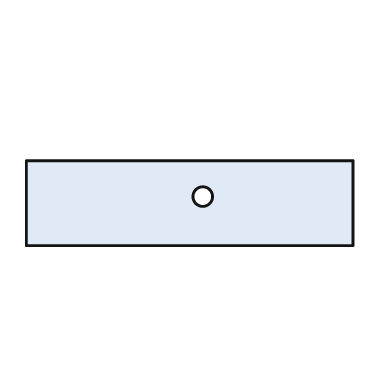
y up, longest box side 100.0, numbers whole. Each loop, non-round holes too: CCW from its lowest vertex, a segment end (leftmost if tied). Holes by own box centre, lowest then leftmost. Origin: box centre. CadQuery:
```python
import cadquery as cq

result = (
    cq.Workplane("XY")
    .moveTo(-50.0, -13.0)
    .lineTo(50.0, -13.0)
    .lineTo(50.0, 13.0)
    .lineTo(-50.0, 13.0)
    .close()
    .moveTo(4.0, 2.0)
    .circle(3.0)
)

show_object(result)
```